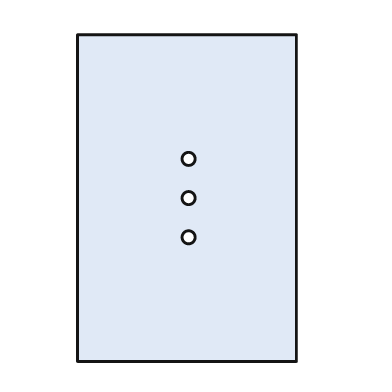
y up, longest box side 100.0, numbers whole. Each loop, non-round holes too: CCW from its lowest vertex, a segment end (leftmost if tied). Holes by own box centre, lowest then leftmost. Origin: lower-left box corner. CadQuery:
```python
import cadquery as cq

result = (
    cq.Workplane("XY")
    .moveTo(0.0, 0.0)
    .lineTo(67.0, 0.0)
    .lineTo(67.0, 100.0)
    .lineTo(0.0, 100.0)
    .close()
    .moveTo(34.0, 38.0)
    .circle(2.0)
    .moveTo(34.0, 50.0)
    .circle(2.0)
    .moveTo(34.0, 62.0)
    .circle(2.0)
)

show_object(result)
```